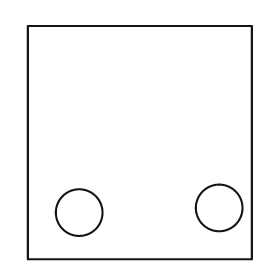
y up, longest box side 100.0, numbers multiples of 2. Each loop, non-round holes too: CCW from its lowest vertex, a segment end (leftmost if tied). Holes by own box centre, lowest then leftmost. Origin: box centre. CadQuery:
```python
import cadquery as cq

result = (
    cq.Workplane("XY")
    .moveTo(-48.0, -50.0)
    .lineTo(48.0, -50.0)
    .lineTo(48.0, 50.0)
    .lineTo(-48.0, 50.0)
    .close()
    .moveTo(-26.0, -30.0)
    .circle(10.0)
    .moveTo(34.0, -28.0)
    .circle(10.0)
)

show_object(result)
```